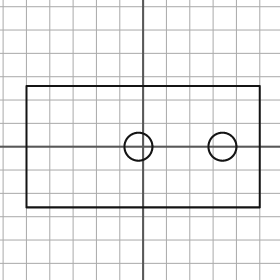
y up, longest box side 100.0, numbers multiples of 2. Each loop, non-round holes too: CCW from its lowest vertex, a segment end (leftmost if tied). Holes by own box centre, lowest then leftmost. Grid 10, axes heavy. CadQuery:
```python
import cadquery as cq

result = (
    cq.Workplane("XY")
    .moveTo(-50.0, -26.0)
    .lineTo(50.0, -26.0)
    .lineTo(50.0, 26.0)
    .lineTo(-50.0, 26.0)
    .close()
    .moveTo(-2.0, 0.0)
    .circle(6.0)
    .moveTo(34.0, 0.0)
    .circle(6.0)
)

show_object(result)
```